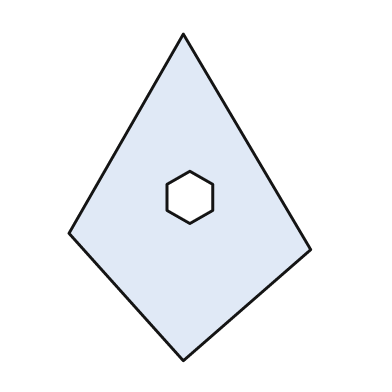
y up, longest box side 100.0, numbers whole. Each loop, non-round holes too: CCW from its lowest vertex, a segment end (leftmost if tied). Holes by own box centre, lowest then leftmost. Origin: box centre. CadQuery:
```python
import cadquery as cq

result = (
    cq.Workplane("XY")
    .moveTo(-2.0, -50.0)
    .lineTo(37.0, -16.0)
    .lineTo(-2.0, 50.0)
    .lineTo(-37.0, -11.0)
    .close()
    .moveTo(0.0, -8.0)
    .lineTo(7.0, -4.0)
    .lineTo(7.0, 4.0)
    .lineTo(0.0, 8.0)
    .lineTo(-7.0, 4.0)
    .lineTo(-7.0, -4.0)
    .close()
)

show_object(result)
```